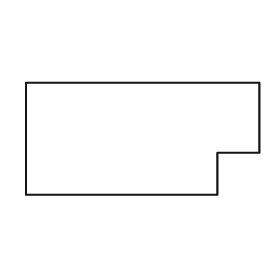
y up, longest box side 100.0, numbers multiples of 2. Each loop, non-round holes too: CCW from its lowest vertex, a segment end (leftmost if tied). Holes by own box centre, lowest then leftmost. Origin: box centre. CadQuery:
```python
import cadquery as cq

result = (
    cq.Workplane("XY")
    .moveTo(-50.0, -24.0)
    .lineTo(32.0, -24.0)
    .lineTo(32.0, -6.0)
    .lineTo(50.0, -6.0)
    .lineTo(50.0, 24.0)
    .lineTo(-50.0, 24.0)
    .close()
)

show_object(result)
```